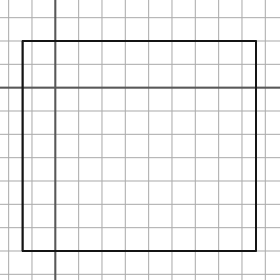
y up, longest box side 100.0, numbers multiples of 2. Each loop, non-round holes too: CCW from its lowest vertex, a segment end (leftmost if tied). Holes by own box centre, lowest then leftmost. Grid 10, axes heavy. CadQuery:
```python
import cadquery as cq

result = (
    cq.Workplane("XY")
    .moveTo(-14.0, -70.0)
    .lineTo(86.0, -70.0)
    .lineTo(86.0, 20.0)
    .lineTo(-14.0, 20.0)
    .close()
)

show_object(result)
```